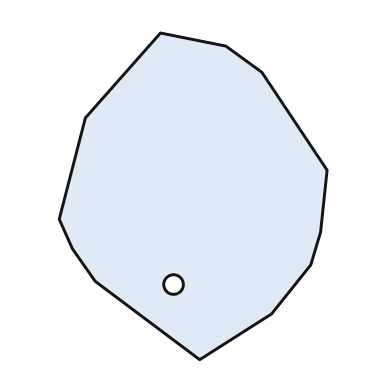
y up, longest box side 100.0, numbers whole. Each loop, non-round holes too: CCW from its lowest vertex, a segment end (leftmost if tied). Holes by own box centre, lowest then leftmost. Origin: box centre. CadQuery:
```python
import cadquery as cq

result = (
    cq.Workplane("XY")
    .moveTo(2.0, -50.0)
    .lineTo(24.0, -36.0)
    .lineTo(36.0, -21.0)
    .lineTo(39.0, -11.0)
    .lineTo(41.0, 8.0)
    .lineTo(21.0, 38.0)
    .lineTo(10.0, 46.0)
    .lineTo(-10.0, 50.0)
    .lineTo(-33.0, 24.0)
    .lineTo(-41.0, -7.0)
    .lineTo(-37.0, -16.0)
    .lineTo(-30.0, -26.0)
    .close()
    .moveTo(-6.0, -27.0)
    .circle(3.0)
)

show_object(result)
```